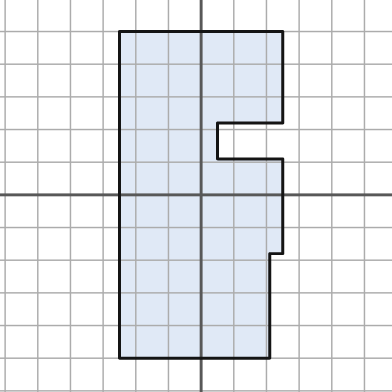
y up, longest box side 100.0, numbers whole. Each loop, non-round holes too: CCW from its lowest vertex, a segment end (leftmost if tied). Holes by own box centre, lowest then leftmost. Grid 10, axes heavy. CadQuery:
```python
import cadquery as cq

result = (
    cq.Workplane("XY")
    .moveTo(-25.0, -50.0)
    .lineTo(21.0, -50.0)
    .lineTo(21.0, -18.0)
    .lineTo(25.0, -18.0)
    .lineTo(25.0, 11.0)
    .lineTo(5.0, 11.0)
    .lineTo(5.0, 22.0)
    .lineTo(25.0, 22.0)
    .lineTo(25.0, 50.0)
    .lineTo(-25.0, 50.0)
    .close()
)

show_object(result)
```